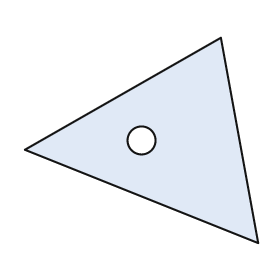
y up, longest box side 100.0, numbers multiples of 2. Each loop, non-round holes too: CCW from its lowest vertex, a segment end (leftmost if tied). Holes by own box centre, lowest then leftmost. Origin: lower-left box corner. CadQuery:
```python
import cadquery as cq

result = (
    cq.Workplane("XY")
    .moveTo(100.0, 0.0)
    .lineTo(84.0, 88.0)
    .lineTo(0.0, 40.0)
    .close()
    .moveTo(50.0, 44.0)
    .circle(6.0)
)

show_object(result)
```